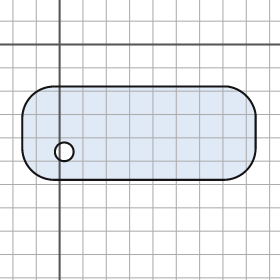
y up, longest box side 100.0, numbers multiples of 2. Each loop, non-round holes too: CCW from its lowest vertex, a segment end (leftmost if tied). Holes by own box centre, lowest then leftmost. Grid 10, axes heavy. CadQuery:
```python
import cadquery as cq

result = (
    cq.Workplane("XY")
    .moveTo(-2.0, -58.0)
    .lineTo(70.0, -58.0)
    .threePointArc((80.0, -54.0), (84.0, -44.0))
    .lineTo(84.0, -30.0)
    .threePointArc((80.0, -22.0), (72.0, -18.0))
    .lineTo(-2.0, -18.0)
    .threePointArc((-12.0, -22.0), (-16.0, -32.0))
    .lineTo(-16.0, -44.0)
    .threePointArc((-12.0, -54.0), (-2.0, -58.0))
    .close()
    .moveTo(2.0, -46.0)
    .circle(4.0)
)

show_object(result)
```